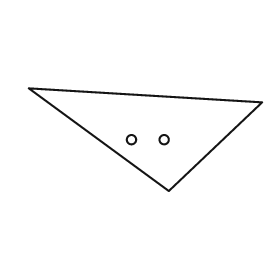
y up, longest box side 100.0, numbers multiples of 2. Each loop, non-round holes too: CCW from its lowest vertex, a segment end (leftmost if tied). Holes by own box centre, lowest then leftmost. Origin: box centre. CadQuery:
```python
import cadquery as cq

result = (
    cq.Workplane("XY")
    .moveTo(10.0, -22.0)
    .lineTo(50.0, 16.0)
    .lineTo(-50.0, 22.0)
    .close()
    .moveTo(-6.0, 0.0)
    .circle(2.0)
    .moveTo(8.0, 0.0)
    .circle(2.0)
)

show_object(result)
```